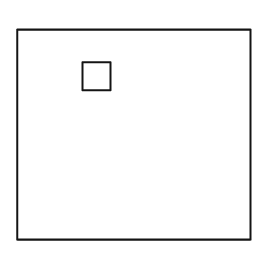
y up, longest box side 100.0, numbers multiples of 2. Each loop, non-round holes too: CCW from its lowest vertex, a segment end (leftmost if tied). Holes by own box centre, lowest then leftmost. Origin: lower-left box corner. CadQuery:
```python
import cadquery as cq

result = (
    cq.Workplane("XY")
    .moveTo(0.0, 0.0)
    .lineTo(100.0, 0.0)
    .lineTo(100.0, 90.0)
    .lineTo(0.0, 90.0)
    .close()
    .moveTo(28.0, 64.0)
    .lineTo(40.0, 64.0)
    .lineTo(40.0, 76.0)
    .lineTo(28.0, 76.0)
    .close()
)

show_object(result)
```